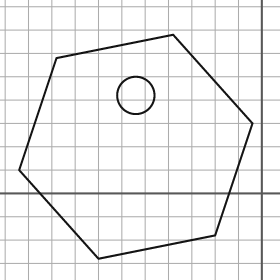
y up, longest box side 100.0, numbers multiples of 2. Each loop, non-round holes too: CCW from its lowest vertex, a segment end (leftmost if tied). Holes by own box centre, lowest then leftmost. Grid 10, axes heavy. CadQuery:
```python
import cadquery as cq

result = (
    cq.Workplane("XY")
    .moveTo(-70.0, -28.0)
    .lineTo(-20.0, -18.0)
    .lineTo(-4.0, 30.0)
    .lineTo(-38.0, 68.0)
    .lineTo(-88.0, 58.0)
    .lineTo(-104.0, 10.0)
    .close()
    .moveTo(-54.0, 42.0)
    .circle(8.0)
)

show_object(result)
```